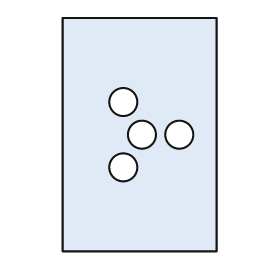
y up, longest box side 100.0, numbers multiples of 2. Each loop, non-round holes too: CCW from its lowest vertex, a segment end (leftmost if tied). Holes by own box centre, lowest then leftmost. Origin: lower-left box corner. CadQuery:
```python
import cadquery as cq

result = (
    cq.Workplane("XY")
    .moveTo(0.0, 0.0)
    .lineTo(66.0, 0.0)
    .lineTo(66.0, 100.0)
    .lineTo(0.0, 100.0)
    .close()
    .moveTo(26.0, 36.0)
    .circle(6.0)
    .moveTo(34.0, 50.0)
    .circle(6.0)
    .moveTo(50.0, 50.0)
    .circle(6.0)
    .moveTo(26.0, 64.0)
    .circle(6.0)
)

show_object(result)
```